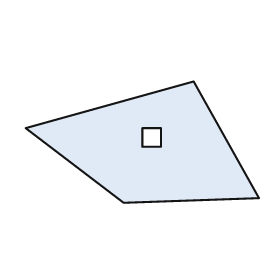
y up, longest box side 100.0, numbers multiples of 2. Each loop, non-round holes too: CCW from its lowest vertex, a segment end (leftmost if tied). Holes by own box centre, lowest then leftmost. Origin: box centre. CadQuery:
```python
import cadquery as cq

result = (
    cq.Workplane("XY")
    .moveTo(-8.0, -26.0)
    .lineTo(50.0, -24.0)
    .lineTo(22.0, 26.0)
    .lineTo(-50.0, 6.0)
    .close()
    .moveTo(0.0, -2.0)
    .lineTo(8.0, -2.0)
    .lineTo(8.0, 6.0)
    .lineTo(0.0, 6.0)
    .close()
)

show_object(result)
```